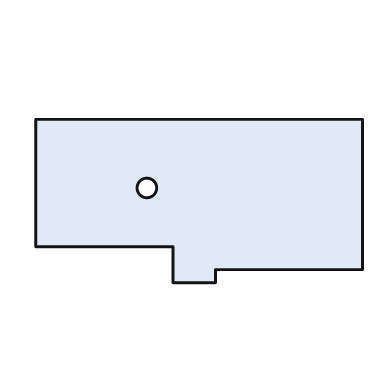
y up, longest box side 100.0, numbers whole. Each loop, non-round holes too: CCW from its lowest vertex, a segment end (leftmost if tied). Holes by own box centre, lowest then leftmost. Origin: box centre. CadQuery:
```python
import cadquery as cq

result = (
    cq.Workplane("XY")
    .moveTo(-8.0, -25.0)
    .lineTo(5.0, -25.0)
    .lineTo(5.0, -21.0)
    .lineTo(50.0, -21.0)
    .lineTo(50.0, 25.0)
    .lineTo(-50.0, 25.0)
    .lineTo(-50.0, -14.0)
    .lineTo(-8.0, -14.0)
    .close()
    .moveTo(-16.0, 4.0)
    .circle(3.0)
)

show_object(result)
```